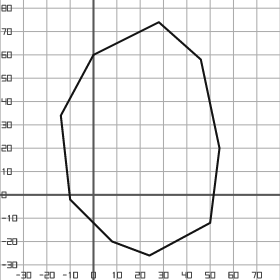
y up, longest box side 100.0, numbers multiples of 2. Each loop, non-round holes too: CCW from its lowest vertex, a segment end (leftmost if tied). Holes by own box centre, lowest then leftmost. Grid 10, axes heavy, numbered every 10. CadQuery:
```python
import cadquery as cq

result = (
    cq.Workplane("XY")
    .moveTo(24.0, -26.0)
    .lineTo(50.0, -12.0)
    .lineTo(54.0, 20.0)
    .lineTo(46.0, 58.0)
    .lineTo(28.0, 74.0)
    .lineTo(0.0, 60.0)
    .lineTo(-14.0, 34.0)
    .lineTo(-10.0, -2.0)
    .lineTo(8.0, -20.0)
    .close()
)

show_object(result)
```